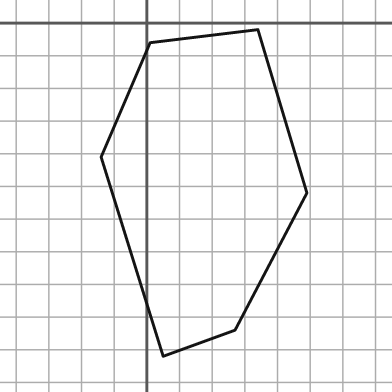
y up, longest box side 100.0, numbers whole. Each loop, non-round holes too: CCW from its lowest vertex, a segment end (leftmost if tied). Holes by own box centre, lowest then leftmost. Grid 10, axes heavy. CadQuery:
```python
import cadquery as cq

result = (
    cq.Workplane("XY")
    .moveTo(5.0, -102.0)
    .lineTo(27.0, -94.0)
    .lineTo(49.0, -52.0)
    .lineTo(34.0, -2.0)
    .lineTo(1.0, -6.0)
    .lineTo(-14.0, -41.0)
    .close()
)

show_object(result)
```